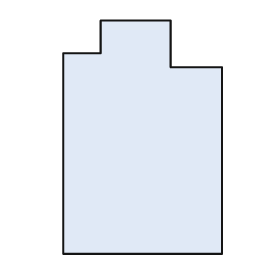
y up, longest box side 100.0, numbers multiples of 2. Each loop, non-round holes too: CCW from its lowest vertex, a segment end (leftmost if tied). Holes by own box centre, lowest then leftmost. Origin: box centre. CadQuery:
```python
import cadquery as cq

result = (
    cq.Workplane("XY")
    .moveTo(-34.0, -50.0)
    .lineTo(34.0, -50.0)
    .lineTo(34.0, 30.0)
    .lineTo(12.0, 30.0)
    .lineTo(12.0, 50.0)
    .lineTo(-18.0, 50.0)
    .lineTo(-18.0, 36.0)
    .lineTo(-34.0, 36.0)
    .close()
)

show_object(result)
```